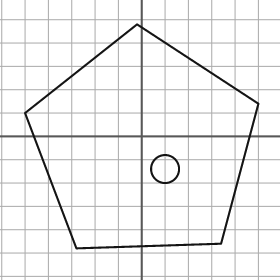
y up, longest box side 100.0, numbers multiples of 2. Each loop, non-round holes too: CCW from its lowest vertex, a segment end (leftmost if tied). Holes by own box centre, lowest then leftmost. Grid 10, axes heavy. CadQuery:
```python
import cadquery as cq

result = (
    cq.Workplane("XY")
    .moveTo(-28.0, -48.0)
    .lineTo(34.0, -46.0)
    .lineTo(50.0, 14.0)
    .lineTo(-2.0, 48.0)
    .lineTo(-50.0, 10.0)
    .close()
    .moveTo(10.0, -14.0)
    .circle(6.0)
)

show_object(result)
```